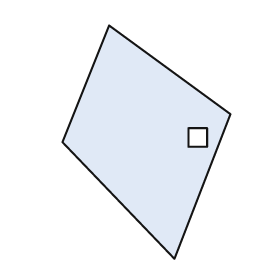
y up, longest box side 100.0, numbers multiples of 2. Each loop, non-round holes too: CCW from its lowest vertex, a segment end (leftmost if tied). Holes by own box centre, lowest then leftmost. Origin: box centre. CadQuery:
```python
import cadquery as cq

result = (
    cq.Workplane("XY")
    .moveTo(12.0, -50.0)
    .lineTo(36.0, 12.0)
    .lineTo(-16.0, 50.0)
    .lineTo(-36.0, 0.0)
    .close()
    .moveTo(18.0, -2.0)
    .lineTo(26.0, -2.0)
    .lineTo(26.0, 6.0)
    .lineTo(18.0, 6.0)
    .close()
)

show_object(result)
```